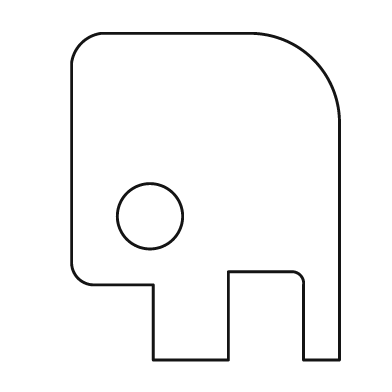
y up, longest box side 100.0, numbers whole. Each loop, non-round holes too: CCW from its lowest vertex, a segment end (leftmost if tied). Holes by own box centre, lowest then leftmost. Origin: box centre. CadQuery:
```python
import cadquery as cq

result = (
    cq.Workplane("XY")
    .moveTo(-16.0, -50.0)
    .lineTo(7.0, -50.0)
    .lineTo(7.0, -23.0)
    .lineTo(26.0, -23.0)
    .threePointArc((29.0, -24.0), (30.0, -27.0))
    .lineTo(30.0, -50.0)
    .lineTo(41.0, -50.0)
    .lineTo(41.0, 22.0)
    .threePointArc((33.0, 42.0), (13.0, 50.0))
    .lineTo(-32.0, 50.0)
    .threePointArc((-38.0, 47.0), (-41.0, 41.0))
    .lineTo(-41.0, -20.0)
    .threePointArc((-39.0, -25.0), (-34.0, -27.0))
    .lineTo(-16.0, -27.0)
    .close()
    .moveTo(-17.0, -6.0)
    .circle(10.0)
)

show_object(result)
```